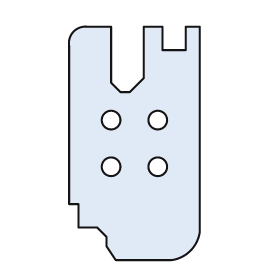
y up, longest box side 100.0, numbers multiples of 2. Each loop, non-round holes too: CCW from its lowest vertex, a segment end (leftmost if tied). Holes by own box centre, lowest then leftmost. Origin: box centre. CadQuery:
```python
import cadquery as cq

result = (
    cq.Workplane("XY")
    .moveTo(-8.0, -50.0)
    .lineTo(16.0, -50.0)
    .threePointArc((24.0, -46.0), (28.0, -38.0))
    .lineTo(28.0, 50.0)
    .lineTo(22.0, 50.0)
    .lineTo(22.0, 40.0)
    .lineTo(12.0, 40.0)
    .lineTo(12.0, 50.0)
    .lineTo(4.0, 50.0)
    .lineTo(4.0, 28.0)
    .lineTo(-2.0, 22.0)
    .lineTo(-6.0, 22.0)
    .lineTo(-10.0, 26.0)
    .lineTo(-10.0, 50.0)
    .lineTo(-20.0, 50.0)
    .threePointArc((-26.0, 48.0), (-28.0, 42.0))
    .lineTo(-28.0, -26.0)
    .lineTo(-24.0, -26.0)
    .lineTo(-24.0, -36.0)
    .lineTo(-16.0, -36.0)
    .lineTo(-12.0, -40.0)
    .lineTo(-12.0, -44.0)
    .close()
    .moveTo(-10.0, -10.0)
    .circle(4.0)
    .moveTo(10.0, -10.0)
    .circle(4.0)
    .moveTo(-10.0, 10.0)
    .circle(4.0)
    .moveTo(10.0, 10.0)
    .circle(4.0)
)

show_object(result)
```